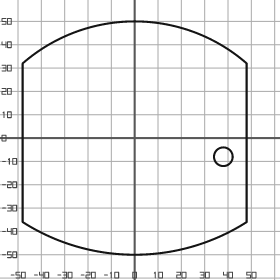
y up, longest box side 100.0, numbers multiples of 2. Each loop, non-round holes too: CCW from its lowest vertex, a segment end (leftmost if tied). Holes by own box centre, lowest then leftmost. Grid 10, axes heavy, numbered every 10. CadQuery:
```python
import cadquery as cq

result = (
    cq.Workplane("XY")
    .moveTo(-48.0, -36.0)
    .threePointArc((0.0, -50.0), (48.0, -36.0))
    .lineTo(48.0, 32.0)
    .threePointArc((0.0, 50.0), (-48.0, 32.0))
    .close()
    .moveTo(38.0, -8.0)
    .circle(4.0)
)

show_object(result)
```